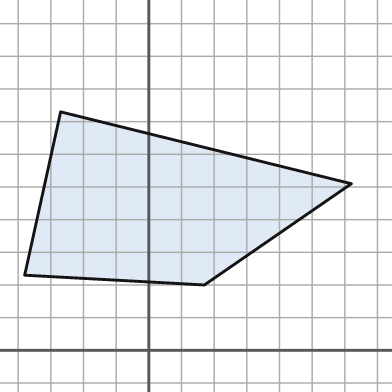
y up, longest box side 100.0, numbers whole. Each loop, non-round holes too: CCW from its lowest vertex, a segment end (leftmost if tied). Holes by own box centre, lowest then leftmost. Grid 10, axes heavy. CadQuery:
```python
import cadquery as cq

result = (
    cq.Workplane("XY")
    .moveTo(17.0, 20.0)
    .lineTo(62.0, 51.0)
    .lineTo(-27.0, 73.0)
    .lineTo(-38.0, 23.0)
    .close()
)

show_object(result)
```